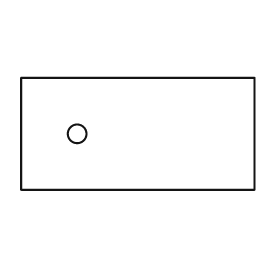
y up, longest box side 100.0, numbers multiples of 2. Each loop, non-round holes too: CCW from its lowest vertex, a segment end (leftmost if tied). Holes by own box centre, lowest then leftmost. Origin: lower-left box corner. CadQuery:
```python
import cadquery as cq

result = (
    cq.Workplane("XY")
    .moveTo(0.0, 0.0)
    .lineTo(100.0, 0.0)
    .lineTo(100.0, 48.0)
    .lineTo(0.0, 48.0)
    .close()
    .moveTo(24.0, 24.0)
    .circle(4.0)
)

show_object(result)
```